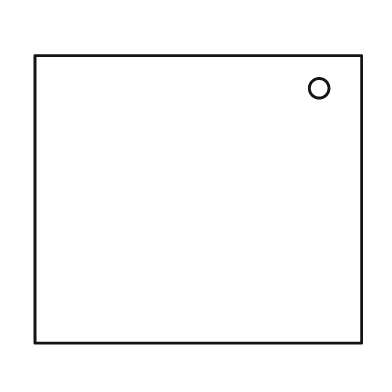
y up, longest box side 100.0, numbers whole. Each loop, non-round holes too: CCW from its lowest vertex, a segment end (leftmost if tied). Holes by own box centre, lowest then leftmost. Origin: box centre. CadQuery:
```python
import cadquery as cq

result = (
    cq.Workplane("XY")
    .moveTo(-50.0, -44.0)
    .lineTo(50.0, -44.0)
    .lineTo(50.0, 44.0)
    .lineTo(-50.0, 44.0)
    .close()
    .moveTo(37.0, 34.0)
    .circle(3.0)
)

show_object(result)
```